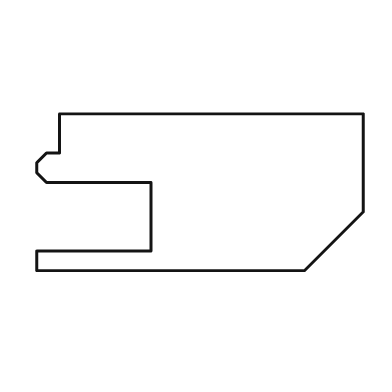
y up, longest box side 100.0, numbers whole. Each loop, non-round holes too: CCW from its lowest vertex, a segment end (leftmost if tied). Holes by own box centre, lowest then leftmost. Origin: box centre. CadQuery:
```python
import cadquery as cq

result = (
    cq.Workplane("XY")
    .moveTo(-50.0, -24.0)
    .lineTo(32.0, -24.0)
    .lineTo(50.0, -6.0)
    .lineTo(50.0, 24.0)
    .lineTo(-43.0, 24.0)
    .lineTo(-43.0, 12.0)
    .lineTo(-47.0, 12.0)
    .lineTo(-50.0, 9.0)
    .lineTo(-50.0, 6.0)
    .lineTo(-47.0, 3.0)
    .lineTo(-15.0, 3.0)
    .lineTo(-15.0, -18.0)
    .lineTo(-50.0, -18.0)
    .close()
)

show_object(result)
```